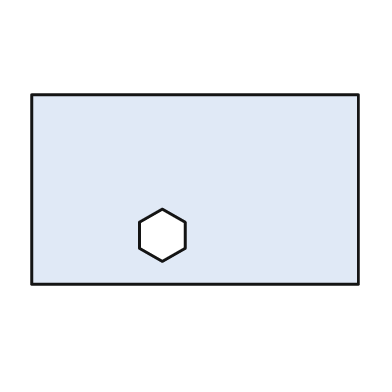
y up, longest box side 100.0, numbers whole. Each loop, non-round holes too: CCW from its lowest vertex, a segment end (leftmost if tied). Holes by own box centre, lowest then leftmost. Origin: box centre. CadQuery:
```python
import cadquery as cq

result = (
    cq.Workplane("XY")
    .moveTo(-50.0, -29.0)
    .lineTo(50.0, -29.0)
    .lineTo(50.0, 29.0)
    .lineTo(-50.0, 29.0)
    .close()
    .moveTo(-10.0, -22.0)
    .lineTo(-3.0, -18.0)
    .lineTo(-3.0, -10.0)
    .lineTo(-10.0, -6.0)
    .lineTo(-17.0, -10.0)
    .lineTo(-17.0, -18.0)
    .close()
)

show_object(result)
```